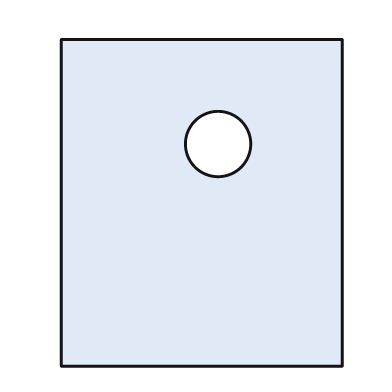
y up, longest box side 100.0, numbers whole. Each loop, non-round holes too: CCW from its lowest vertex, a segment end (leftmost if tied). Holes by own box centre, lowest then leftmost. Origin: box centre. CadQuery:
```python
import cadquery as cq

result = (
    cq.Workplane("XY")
    .moveTo(-43.0, -50.0)
    .lineTo(43.0, -50.0)
    .lineTo(43.0, 50.0)
    .lineTo(-43.0, 50.0)
    .close()
    .moveTo(5.0, 18.0)
    .circle(10.0)
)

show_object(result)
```